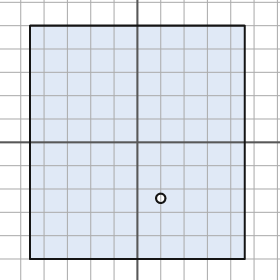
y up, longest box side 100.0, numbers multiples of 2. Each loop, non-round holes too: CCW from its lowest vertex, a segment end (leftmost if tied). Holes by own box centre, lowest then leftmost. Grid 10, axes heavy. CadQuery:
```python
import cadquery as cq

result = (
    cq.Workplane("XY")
    .moveTo(-46.0, -50.0)
    .lineTo(46.0, -50.0)
    .lineTo(46.0, 50.0)
    .lineTo(-46.0, 50.0)
    .close()
    .moveTo(10.0, -24.0)
    .circle(2.0)
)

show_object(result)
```